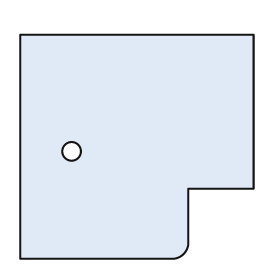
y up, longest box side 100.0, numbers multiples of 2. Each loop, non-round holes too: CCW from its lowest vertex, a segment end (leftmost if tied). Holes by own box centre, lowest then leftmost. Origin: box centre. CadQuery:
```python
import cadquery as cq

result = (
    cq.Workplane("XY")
    .moveTo(-50.0, -48.0)
    .lineTo(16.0, -48.0)
    .threePointArc((20.0, -46.0), (22.0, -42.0))
    .lineTo(22.0, -18.0)
    .lineTo(50.0, -18.0)
    .lineTo(50.0, 48.0)
    .lineTo(-50.0, 48.0)
    .close()
    .moveTo(-28.0, -2.0)
    .circle(4.0)
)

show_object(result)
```